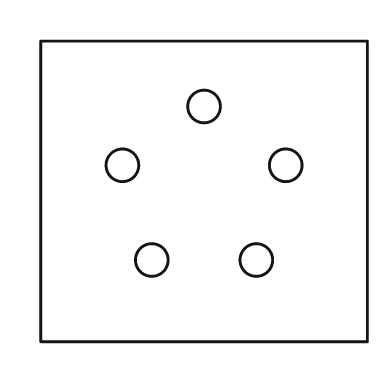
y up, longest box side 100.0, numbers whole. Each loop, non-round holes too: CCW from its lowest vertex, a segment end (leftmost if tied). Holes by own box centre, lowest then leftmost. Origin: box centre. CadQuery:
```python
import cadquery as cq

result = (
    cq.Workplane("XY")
    .moveTo(-50.0, -46.0)
    .lineTo(50.0, -46.0)
    .lineTo(50.0, 46.0)
    .lineTo(-50.0, 46.0)
    .close()
    .moveTo(-16.0, -21.0)
    .circle(5.0)
    .moveTo(16.0, -21.0)
    .circle(5.0)
    .moveTo(-25.0, 8.0)
    .circle(5.0)
    .moveTo(25.0, 8.0)
    .circle(5.0)
    .moveTo(0.0, 26.0)
    .circle(5.0)
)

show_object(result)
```